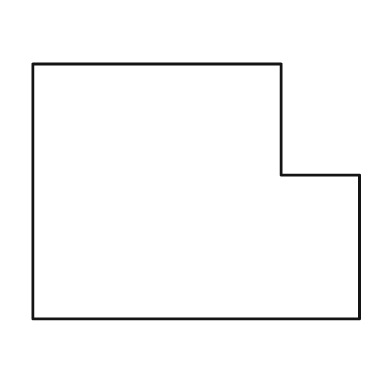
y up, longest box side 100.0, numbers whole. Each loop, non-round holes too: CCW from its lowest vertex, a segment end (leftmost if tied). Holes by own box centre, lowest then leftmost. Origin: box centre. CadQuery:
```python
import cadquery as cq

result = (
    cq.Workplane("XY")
    .moveTo(-50.0, -39.0)
    .lineTo(50.0, -39.0)
    .lineTo(50.0, 5.0)
    .lineTo(26.0, 5.0)
    .lineTo(26.0, 39.0)
    .lineTo(-50.0, 39.0)
    .close()
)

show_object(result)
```